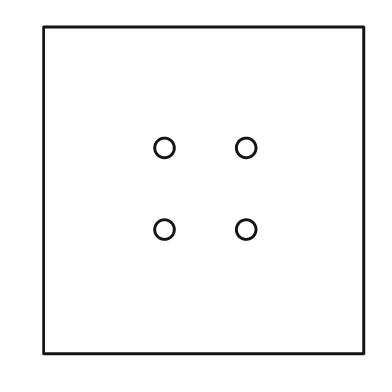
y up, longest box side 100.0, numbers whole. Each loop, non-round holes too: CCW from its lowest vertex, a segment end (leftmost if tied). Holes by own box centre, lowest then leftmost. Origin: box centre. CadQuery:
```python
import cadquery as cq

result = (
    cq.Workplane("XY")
    .moveTo(-49.0, -50.0)
    .lineTo(49.0, -50.0)
    .lineTo(49.0, 50.0)
    .lineTo(-49.0, 50.0)
    .close()
    .moveTo(-12.0, -12.0)
    .circle(3.0)
    .moveTo(13.0, -12.0)
    .circle(3.0)
    .moveTo(-12.0, 13.0)
    .circle(3.0)
    .moveTo(13.0, 13.0)
    .circle(3.0)
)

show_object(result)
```